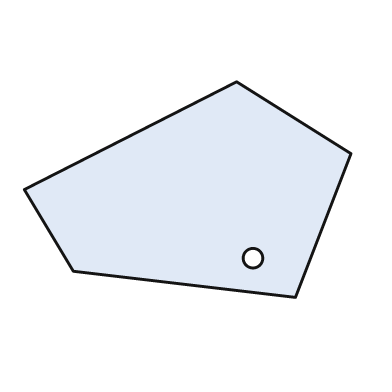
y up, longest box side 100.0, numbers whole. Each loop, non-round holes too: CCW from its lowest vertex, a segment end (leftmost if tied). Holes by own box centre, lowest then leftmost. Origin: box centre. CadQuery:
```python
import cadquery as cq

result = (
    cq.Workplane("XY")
    .moveTo(33.0, -33.0)
    .lineTo(50.0, 11.0)
    .lineTo(15.0, 33.0)
    .lineTo(-50.0, 0.0)
    .lineTo(-35.0, -25.0)
    .close()
    .moveTo(20.0, -21.0)
    .circle(3.0)
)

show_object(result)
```